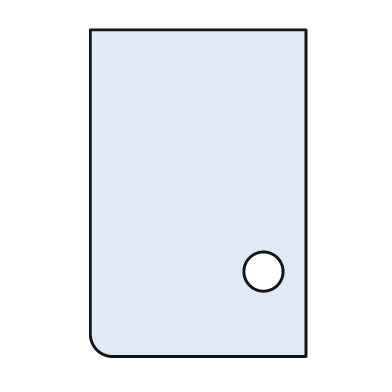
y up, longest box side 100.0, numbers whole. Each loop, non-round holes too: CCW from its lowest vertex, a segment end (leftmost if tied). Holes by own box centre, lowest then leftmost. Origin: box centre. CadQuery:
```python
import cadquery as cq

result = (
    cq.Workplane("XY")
    .moveTo(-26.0, -50.0)
    .lineTo(33.0, -50.0)
    .lineTo(33.0, 50.0)
    .lineTo(-33.0, 50.0)
    .lineTo(-33.0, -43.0)
    .threePointArc((-31.0, -48.0), (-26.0, -50.0))
    .close()
    .moveTo(20.0, -24.0)
    .circle(6.0)
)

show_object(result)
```